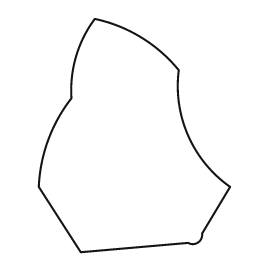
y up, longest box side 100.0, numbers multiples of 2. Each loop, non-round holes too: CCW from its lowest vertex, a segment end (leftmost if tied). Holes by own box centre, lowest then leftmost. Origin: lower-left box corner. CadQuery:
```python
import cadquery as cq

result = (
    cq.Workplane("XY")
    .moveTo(18.0, 0.0)
    .lineTo(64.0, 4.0)
    .threePointArc((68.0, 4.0), (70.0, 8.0))
    .lineTo(82.0, 28.0)
    .threePointArc((64.0, 50.0), (60.0, 78.0))
    .threePointArc((44.0, 92.0), (24.0, 100.0))
    .threePointArc((16.0, 84.0), (14.0, 66.0))
    .threePointArc((4.0, 48.0), (0.0, 28.0))
    .close()
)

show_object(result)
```